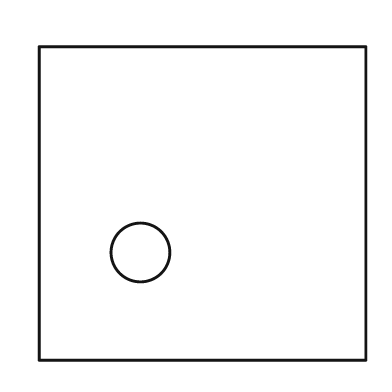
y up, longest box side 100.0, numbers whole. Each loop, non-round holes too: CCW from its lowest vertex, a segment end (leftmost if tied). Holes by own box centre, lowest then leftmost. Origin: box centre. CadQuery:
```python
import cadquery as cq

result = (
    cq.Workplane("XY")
    .moveTo(-50.0, -48.0)
    .lineTo(50.0, -48.0)
    .lineTo(50.0, 48.0)
    .lineTo(-50.0, 48.0)
    .close()
    .moveTo(-19.0, -15.0)
    .circle(9.0)
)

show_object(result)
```